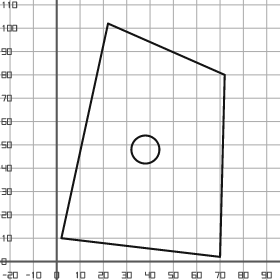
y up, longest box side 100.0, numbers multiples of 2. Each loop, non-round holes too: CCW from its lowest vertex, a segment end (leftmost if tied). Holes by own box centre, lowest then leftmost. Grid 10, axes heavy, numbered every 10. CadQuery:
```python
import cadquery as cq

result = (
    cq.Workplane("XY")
    .moveTo(70.0, 2.0)
    .lineTo(72.0, 80.0)
    .lineTo(22.0, 102.0)
    .lineTo(2.0, 10.0)
    .close()
    .moveTo(38.0, 48.0)
    .circle(6.0)
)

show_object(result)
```